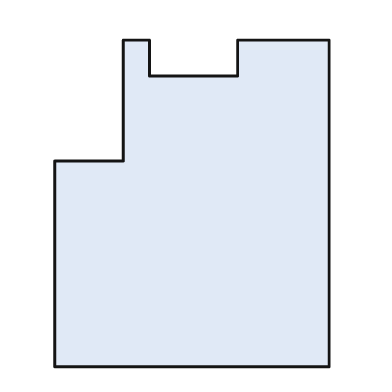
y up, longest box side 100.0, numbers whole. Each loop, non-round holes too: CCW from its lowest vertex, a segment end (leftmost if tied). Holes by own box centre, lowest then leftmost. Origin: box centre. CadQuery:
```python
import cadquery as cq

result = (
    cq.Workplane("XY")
    .moveTo(-42.0, -50.0)
    .lineTo(42.0, -50.0)
    .lineTo(42.0, 50.0)
    .lineTo(14.0, 50.0)
    .lineTo(14.0, 39.0)
    .lineTo(-13.0, 39.0)
    .lineTo(-13.0, 50.0)
    .lineTo(-21.0, 50.0)
    .lineTo(-21.0, 13.0)
    .lineTo(-42.0, 13.0)
    .close()
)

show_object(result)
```